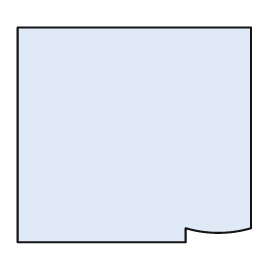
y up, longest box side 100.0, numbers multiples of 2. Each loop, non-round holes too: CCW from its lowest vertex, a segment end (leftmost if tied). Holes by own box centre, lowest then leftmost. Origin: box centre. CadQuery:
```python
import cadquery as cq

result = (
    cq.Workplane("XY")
    .moveTo(-50.0, -46.0)
    .lineTo(22.0, -46.0)
    .lineTo(22.0, -40.0)
    .threePointArc((36.0, -42.0), (50.0, -40.0))
    .lineTo(50.0, 46.0)
    .lineTo(-50.0, 46.0)
    .close()
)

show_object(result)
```